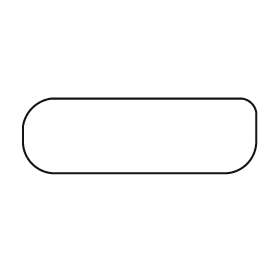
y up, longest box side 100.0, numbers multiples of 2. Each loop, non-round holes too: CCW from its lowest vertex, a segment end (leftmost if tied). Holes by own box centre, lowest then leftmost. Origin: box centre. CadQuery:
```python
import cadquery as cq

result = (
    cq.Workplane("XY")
    .moveTo(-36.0, -16.0)
    .lineTo(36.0, -16.0)
    .threePointArc((46.0, -12.0), (50.0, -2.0))
    .lineTo(50.0, 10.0)
    .threePointArc((48.0, 14.0), (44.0, 16.0))
    .lineTo(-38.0, 16.0)
    .threePointArc((-46.0, 12.0), (-50.0, 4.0))
    .lineTo(-50.0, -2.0)
    .threePointArc((-46.0, -12.0), (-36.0, -16.0))
    .close()
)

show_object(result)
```